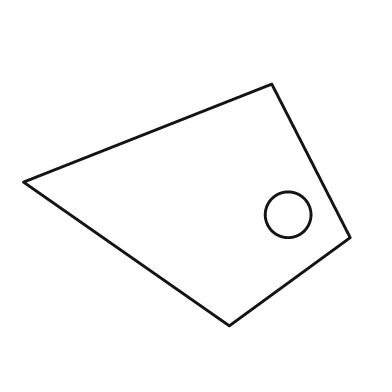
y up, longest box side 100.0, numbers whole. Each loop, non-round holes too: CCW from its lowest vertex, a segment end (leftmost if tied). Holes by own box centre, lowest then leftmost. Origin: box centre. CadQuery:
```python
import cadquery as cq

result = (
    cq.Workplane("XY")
    .moveTo(13.0, -37.0)
    .lineTo(50.0, -10.0)
    .lineTo(26.0, 37.0)
    .lineTo(-50.0, 7.0)
    .close()
    .moveTo(31.0, -3.0)
    .circle(7.0)
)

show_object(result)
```